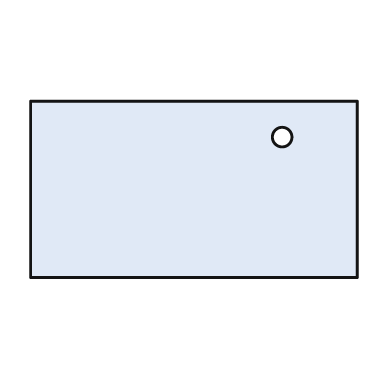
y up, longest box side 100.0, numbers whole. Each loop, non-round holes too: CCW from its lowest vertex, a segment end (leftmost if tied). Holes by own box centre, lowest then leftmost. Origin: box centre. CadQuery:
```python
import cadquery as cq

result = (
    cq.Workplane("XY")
    .moveTo(-50.0, -27.0)
    .lineTo(50.0, -27.0)
    .lineTo(50.0, 27.0)
    .lineTo(-50.0, 27.0)
    .close()
    .moveTo(27.0, 16.0)
    .circle(3.0)
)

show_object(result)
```